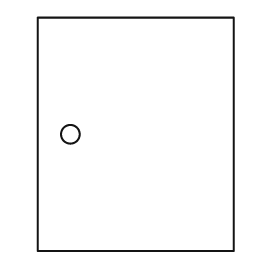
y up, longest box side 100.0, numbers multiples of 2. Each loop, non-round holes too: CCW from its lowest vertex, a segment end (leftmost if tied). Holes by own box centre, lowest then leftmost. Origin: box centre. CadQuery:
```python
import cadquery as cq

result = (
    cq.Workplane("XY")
    .moveTo(-42.0, -50.0)
    .lineTo(42.0, -50.0)
    .lineTo(42.0, 50.0)
    .lineTo(-42.0, 50.0)
    .close()
    .moveTo(-28.0, 0.0)
    .circle(4.0)
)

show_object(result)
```